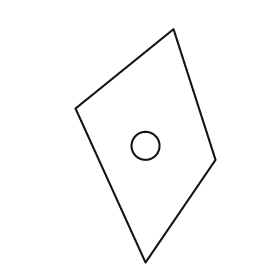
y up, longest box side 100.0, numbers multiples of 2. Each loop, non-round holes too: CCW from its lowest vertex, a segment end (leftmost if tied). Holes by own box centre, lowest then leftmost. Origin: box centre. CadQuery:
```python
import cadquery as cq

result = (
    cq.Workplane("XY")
    .moveTo(0.0, -50.0)
    .lineTo(30.0, -6.0)
    .lineTo(12.0, 50.0)
    .lineTo(-30.0, 16.0)
    .close()
    .moveTo(0.0, 0.0)
    .circle(6.0)
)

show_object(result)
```